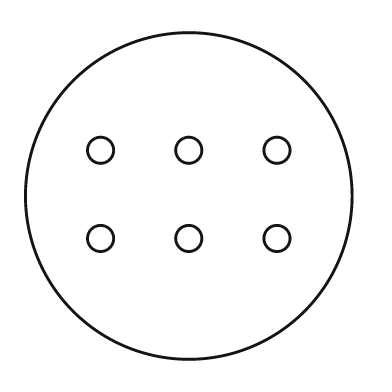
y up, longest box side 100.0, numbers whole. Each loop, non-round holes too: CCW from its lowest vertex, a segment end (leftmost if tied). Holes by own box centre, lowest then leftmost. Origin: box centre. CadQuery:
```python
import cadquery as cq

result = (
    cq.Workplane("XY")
    .moveTo(0.0, 0.0)
    .circle(50.0)
    .moveTo(-27.0, -13.0)
    .circle(4.0)
    .moveTo(0.0, -13.0)
    .circle(4.0)
    .moveTo(27.0, -13.0)
    .circle(4.0)
    .moveTo(-27.0, 14.0)
    .circle(4.0)
    .moveTo(0.0, 14.0)
    .circle(4.0)
    .moveTo(27.0, 14.0)
    .circle(4.0)
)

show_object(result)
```